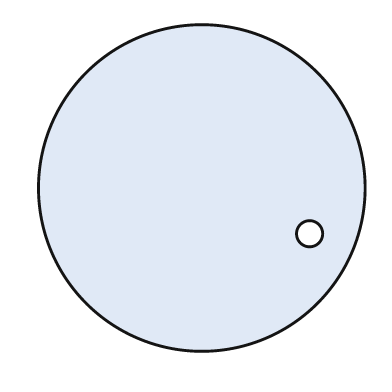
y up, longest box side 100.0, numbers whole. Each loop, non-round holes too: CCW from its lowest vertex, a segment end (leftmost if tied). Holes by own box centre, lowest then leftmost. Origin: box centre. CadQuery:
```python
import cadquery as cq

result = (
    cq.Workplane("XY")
    .moveTo(0.0, 0.0)
    .circle(50.0)
    .moveTo(33.0, -14.0)
    .circle(4.0)
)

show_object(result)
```